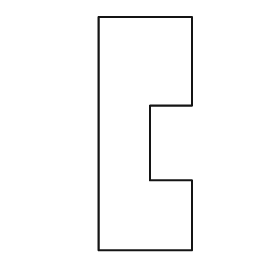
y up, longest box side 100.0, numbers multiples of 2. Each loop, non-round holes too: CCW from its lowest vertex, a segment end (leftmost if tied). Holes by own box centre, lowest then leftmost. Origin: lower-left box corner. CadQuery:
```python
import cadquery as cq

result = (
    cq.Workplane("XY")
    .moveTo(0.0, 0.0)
    .lineTo(40.0, 0.0)
    .lineTo(40.0, 30.0)
    .lineTo(22.0, 30.0)
    .lineTo(22.0, 62.0)
    .lineTo(40.0, 62.0)
    .lineTo(40.0, 100.0)
    .lineTo(0.0, 100.0)
    .close()
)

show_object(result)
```